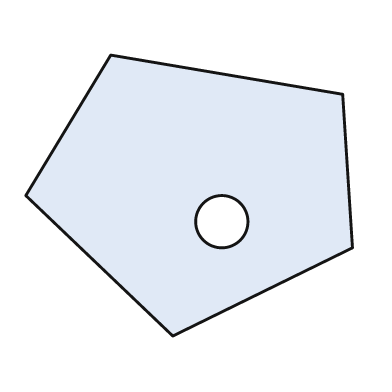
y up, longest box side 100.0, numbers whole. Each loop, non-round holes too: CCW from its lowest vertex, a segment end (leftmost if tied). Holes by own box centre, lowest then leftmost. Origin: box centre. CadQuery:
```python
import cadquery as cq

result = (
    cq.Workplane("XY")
    .moveTo(-5.0, -43.0)
    .lineTo(50.0, -16.0)
    .lineTo(47.0, 31.0)
    .lineTo(-24.0, 43.0)
    .lineTo(-50.0, 0.0)
    .close()
    .moveTo(10.0, -8.0)
    .circle(8.0)
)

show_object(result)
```